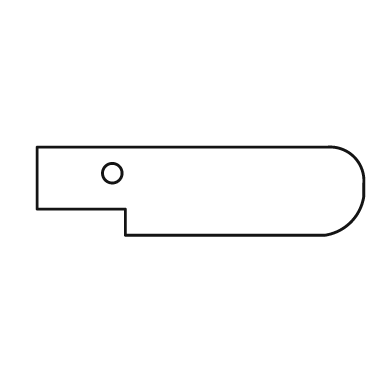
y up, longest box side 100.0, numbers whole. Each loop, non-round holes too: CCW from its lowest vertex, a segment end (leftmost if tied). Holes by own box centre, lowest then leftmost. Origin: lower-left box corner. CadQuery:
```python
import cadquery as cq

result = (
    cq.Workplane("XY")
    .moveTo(27.0, 0.0)
    .lineTo(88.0, 0.0)
    .threePointArc((96.0, 4.0), (100.0, 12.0))
    .lineTo(100.0, 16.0)
    .threePointArc((97.0, 24.0), (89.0, 27.0))
    .lineTo(0.0, 27.0)
    .lineTo(0.0, 8.0)
    .lineTo(27.0, 8.0)
    .close()
    .moveTo(23.0, 19.0)
    .circle(3.0)
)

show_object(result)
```